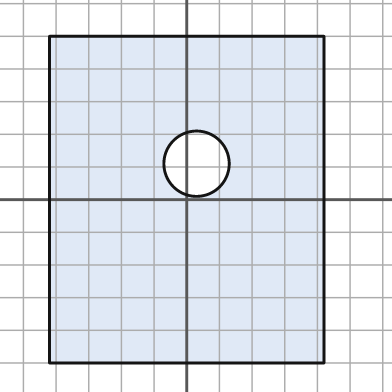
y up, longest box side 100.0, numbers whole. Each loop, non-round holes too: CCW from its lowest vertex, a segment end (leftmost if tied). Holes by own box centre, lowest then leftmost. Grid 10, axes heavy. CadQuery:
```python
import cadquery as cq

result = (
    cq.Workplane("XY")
    .moveTo(-42.0, -50.0)
    .lineTo(42.0, -50.0)
    .lineTo(42.0, 50.0)
    .lineTo(-42.0, 50.0)
    .close()
    .moveTo(3.0, 11.0)
    .circle(10.0)
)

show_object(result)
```